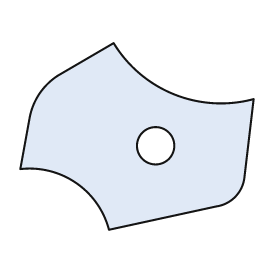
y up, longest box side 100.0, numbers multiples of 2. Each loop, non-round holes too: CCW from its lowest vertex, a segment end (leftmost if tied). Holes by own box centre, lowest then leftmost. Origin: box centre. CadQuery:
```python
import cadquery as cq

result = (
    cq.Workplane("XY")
    .moveTo(-12.0, -40.0)
    .lineTo(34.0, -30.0)
    .threePointArc((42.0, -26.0), (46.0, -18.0))
    .lineTo(50.0, 16.0)
    .threePointArc((16.0, 18.0), (-10.0, 40.0))
    .lineTo(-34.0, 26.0)
    .threePointArc((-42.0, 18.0), (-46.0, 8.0))
    .lineTo(-50.0, -14.0)
    .threePointArc((-26.0, -20.0), (-12.0, -40.0))
    .close()
    .moveTo(8.0, -4.0)
    .circle(8.0)
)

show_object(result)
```